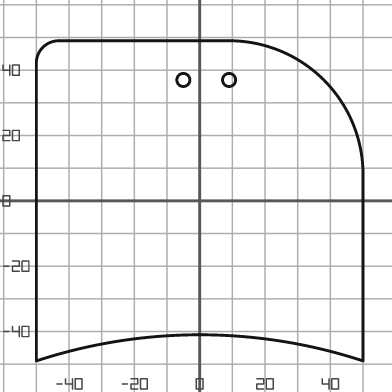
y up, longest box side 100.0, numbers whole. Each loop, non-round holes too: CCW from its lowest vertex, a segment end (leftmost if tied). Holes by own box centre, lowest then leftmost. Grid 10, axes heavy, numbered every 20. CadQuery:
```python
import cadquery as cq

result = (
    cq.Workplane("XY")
    .moveTo(-50.0, -49.0)
    .threePointArc((0.0, -41.0), (50.0, -49.0))
    .lineTo(50.0, 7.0)
    .threePointArc((38.0, 37.0), (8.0, 49.0))
    .lineTo(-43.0, 49.0)
    .threePointArc((-48.0, 47.0), (-50.0, 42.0))
    .close()
    .moveTo(-5.0, 37.0)
    .circle(2.0)
    .moveTo(9.0, 37.0)
    .circle(2.0)
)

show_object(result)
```